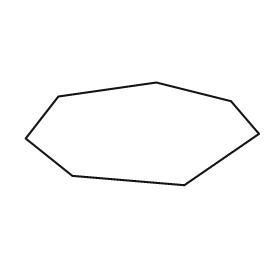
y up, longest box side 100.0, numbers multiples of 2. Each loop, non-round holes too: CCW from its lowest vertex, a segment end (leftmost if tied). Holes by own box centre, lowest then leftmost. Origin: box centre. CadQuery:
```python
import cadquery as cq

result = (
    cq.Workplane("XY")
    .moveTo(18.0, -22.0)
    .lineTo(50.0, 0.0)
    .lineTo(38.0, 14.0)
    .lineTo(6.0, 22.0)
    .lineTo(-36.0, 16.0)
    .lineTo(-50.0, -2.0)
    .lineTo(-30.0, -18.0)
    .close()
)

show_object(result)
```